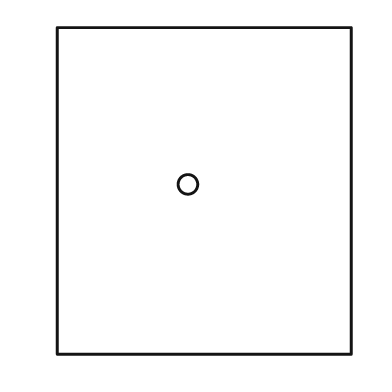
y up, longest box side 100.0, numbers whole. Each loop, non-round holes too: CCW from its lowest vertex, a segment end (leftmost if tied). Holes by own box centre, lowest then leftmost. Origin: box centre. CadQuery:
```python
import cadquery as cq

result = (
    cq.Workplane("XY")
    .moveTo(-45.0, -50.0)
    .lineTo(45.0, -50.0)
    .lineTo(45.0, 50.0)
    .lineTo(-45.0, 50.0)
    .close()
    .moveTo(-5.0, 2.0)
    .circle(3.0)
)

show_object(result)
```